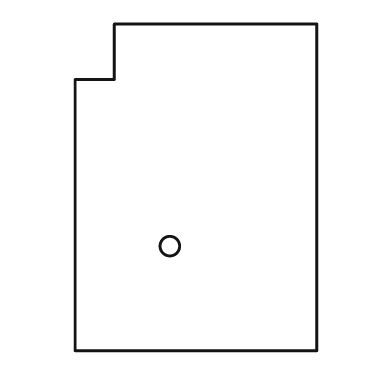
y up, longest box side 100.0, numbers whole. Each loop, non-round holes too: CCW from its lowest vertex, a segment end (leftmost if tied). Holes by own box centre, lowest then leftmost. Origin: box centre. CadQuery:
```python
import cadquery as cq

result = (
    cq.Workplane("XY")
    .moveTo(-37.0, -50.0)
    .lineTo(37.0, -50.0)
    .lineTo(37.0, 50.0)
    .lineTo(-25.0, 50.0)
    .lineTo(-25.0, 33.0)
    .lineTo(-37.0, 33.0)
    .close()
    .moveTo(-8.0, -18.0)
    .circle(3.0)
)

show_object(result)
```